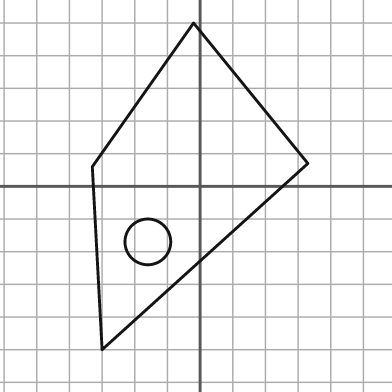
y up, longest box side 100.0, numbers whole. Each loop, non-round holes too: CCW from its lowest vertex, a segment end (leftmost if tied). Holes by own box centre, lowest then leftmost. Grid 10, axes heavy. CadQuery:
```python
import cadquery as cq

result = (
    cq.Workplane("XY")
    .moveTo(-30.0, -50.0)
    .lineTo(33.0, 7.0)
    .lineTo(-2.0, 50.0)
    .lineTo(-33.0, 6.0)
    .close()
    .moveTo(-16.0, -17.0)
    .circle(7.0)
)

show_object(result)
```